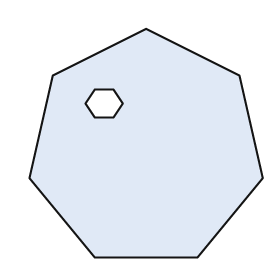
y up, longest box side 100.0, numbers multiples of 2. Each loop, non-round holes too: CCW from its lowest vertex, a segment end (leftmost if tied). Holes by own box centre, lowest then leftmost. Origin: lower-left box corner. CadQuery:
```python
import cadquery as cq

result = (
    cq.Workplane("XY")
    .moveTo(28.0, 0.0)
    .lineTo(72.0, 0.0)
    .lineTo(100.0, 34.0)
    .lineTo(90.0, 78.0)
    .lineTo(50.0, 98.0)
    .lineTo(10.0, 78.0)
    .lineTo(0.0, 34.0)
    .close()
    .moveTo(28.0, 60.0)
    .lineTo(36.0, 60.0)
    .lineTo(40.0, 66.0)
    .lineTo(36.0, 72.0)
    .lineTo(28.0, 72.0)
    .lineTo(24.0, 66.0)
    .close()
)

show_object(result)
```